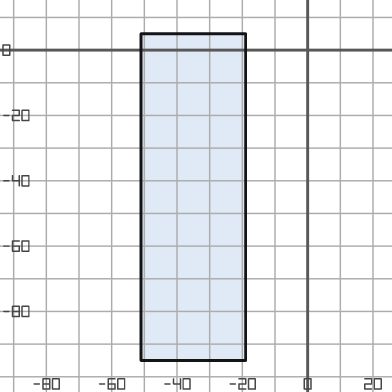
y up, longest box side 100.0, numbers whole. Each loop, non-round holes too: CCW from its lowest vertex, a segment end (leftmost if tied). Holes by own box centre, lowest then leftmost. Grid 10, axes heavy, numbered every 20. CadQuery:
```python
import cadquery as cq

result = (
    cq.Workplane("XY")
    .moveTo(-51.0, -95.0)
    .lineTo(-19.0, -95.0)
    .lineTo(-19.0, 5.0)
    .lineTo(-51.0, 5.0)
    .close()
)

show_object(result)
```